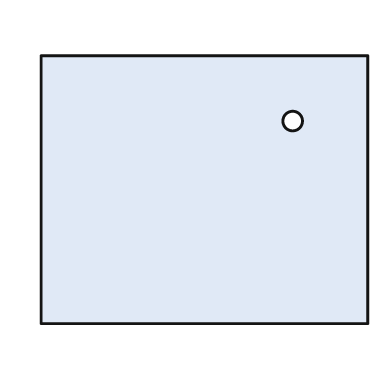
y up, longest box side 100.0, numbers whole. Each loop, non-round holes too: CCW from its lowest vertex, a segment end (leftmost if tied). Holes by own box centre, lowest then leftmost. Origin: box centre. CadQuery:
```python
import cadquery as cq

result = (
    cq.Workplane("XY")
    .moveTo(-50.0, -41.0)
    .lineTo(50.0, -41.0)
    .lineTo(50.0, 41.0)
    .lineTo(-50.0, 41.0)
    .close()
    .moveTo(27.0, 21.0)
    .circle(3.0)
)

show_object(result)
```